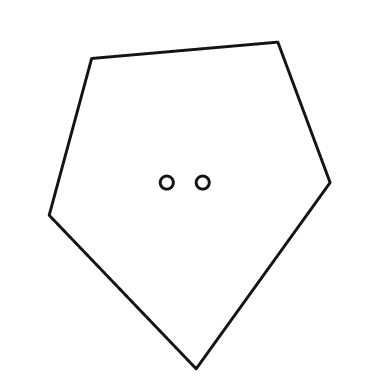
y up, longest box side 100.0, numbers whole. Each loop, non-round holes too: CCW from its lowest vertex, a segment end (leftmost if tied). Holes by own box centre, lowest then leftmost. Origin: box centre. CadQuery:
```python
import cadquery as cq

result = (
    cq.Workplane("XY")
    .moveTo(2.0, -50.0)
    .lineTo(43.0, 7.0)
    .lineTo(27.0, 50.0)
    .lineTo(-30.0, 45.0)
    .lineTo(-43.0, -3.0)
    .close()
    .moveTo(-7.0, 7.0)
    .circle(2.0)
    .moveTo(4.0, 7.0)
    .circle(2.0)
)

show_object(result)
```